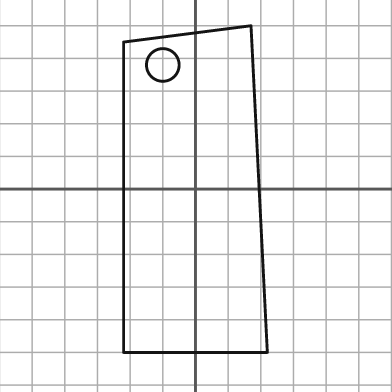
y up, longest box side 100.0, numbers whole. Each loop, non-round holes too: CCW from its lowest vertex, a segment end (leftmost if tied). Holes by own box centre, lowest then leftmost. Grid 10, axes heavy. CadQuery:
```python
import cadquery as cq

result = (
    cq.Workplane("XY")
    .moveTo(-22.0, -50.0)
    .lineTo(22.0, -50.0)
    .lineTo(17.0, 50.0)
    .lineTo(-22.0, 45.0)
    .close()
    .moveTo(-10.0, 38.0)
    .circle(5.0)
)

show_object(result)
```